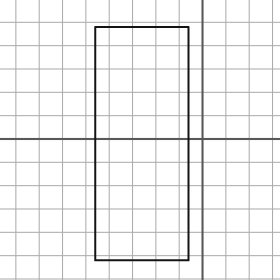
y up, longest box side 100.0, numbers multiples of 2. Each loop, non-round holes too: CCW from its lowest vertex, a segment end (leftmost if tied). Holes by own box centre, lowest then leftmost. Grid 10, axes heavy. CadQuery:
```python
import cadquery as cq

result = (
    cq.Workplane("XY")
    .moveTo(-46.0, -52.0)
    .lineTo(-6.0, -52.0)
    .lineTo(-6.0, 48.0)
    .lineTo(-46.0, 48.0)
    .close()
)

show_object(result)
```